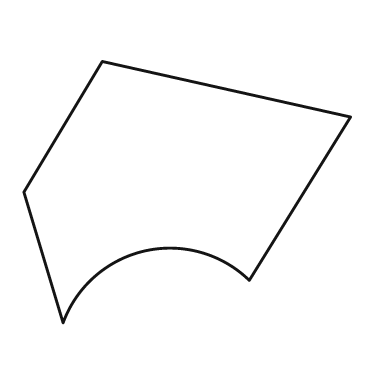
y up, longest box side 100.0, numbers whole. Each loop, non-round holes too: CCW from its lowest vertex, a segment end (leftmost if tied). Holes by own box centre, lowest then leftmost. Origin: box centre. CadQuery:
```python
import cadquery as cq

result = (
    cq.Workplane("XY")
    .moveTo(-38.0, -40.0)
    .threePointArc((-13.0, -18.0), (19.0, -27.0))
    .lineTo(50.0, 23.0)
    .lineTo(-26.0, 40.0)
    .lineTo(-50.0, 0.0)
    .close()
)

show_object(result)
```